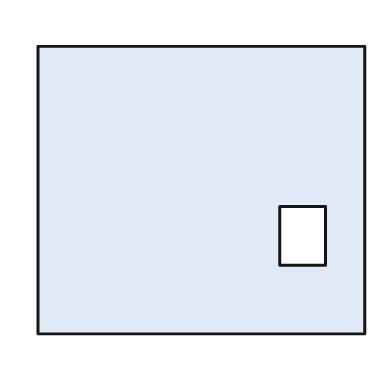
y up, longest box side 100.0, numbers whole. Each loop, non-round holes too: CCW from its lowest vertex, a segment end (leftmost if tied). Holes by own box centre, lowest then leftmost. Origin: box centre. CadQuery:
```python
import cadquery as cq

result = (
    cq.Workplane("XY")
    .moveTo(-50.0, -44.0)
    .lineTo(50.0, -44.0)
    .lineTo(50.0, 44.0)
    .lineTo(-50.0, 44.0)
    .close()
    .moveTo(24.0, -23.0)
    .lineTo(38.0, -23.0)
    .lineTo(38.0, -5.0)
    .lineTo(24.0, -5.0)
    .close()
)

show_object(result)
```